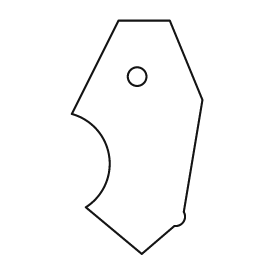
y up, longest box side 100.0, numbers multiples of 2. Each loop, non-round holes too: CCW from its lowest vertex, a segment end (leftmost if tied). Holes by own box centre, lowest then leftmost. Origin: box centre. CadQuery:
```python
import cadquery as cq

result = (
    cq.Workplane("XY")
    .moveTo(2.0, -50.0)
    .lineTo(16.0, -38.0)
    .threePointArc((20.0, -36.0), (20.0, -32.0))
    .lineTo(28.0, 16.0)
    .lineTo(14.0, 50.0)
    .lineTo(-8.0, 50.0)
    .lineTo(-28.0, 10.0)
    .threePointArc((-12.0, -8.0), (-22.0, -30.0))
    .close()
    .moveTo(0.0, 26.0)
    .circle(4.0)
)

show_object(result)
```